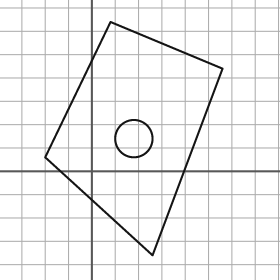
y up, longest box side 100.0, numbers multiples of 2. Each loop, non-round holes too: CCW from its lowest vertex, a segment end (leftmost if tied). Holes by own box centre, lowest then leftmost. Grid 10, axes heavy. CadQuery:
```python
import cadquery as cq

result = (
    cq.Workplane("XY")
    .moveTo(26.0, -36.0)
    .lineTo(56.0, 44.0)
    .lineTo(8.0, 64.0)
    .lineTo(-20.0, 6.0)
    .close()
    .moveTo(18.0, 14.0)
    .circle(8.0)
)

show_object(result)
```